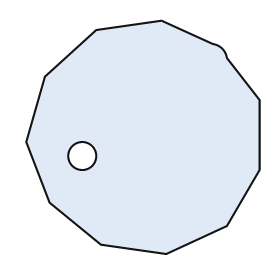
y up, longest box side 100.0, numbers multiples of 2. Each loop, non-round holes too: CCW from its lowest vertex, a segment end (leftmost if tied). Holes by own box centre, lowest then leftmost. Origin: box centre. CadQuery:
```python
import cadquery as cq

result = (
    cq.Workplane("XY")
    .moveTo(10.0, -50.0)
    .lineTo(36.0, -38.0)
    .lineTo(50.0, -14.0)
    .lineTo(50.0, 16.0)
    .lineTo(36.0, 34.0)
    .threePointArc((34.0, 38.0), (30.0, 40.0))
    .lineTo(8.0, 50.0)
    .lineTo(-20.0, 46.0)
    .lineTo(-42.0, 26.0)
    .lineTo(-50.0, -2.0)
    .lineTo(-40.0, -28.0)
    .lineTo(-18.0, -46.0)
    .close()
    .moveTo(-26.0, -8.0)
    .circle(6.0)
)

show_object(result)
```